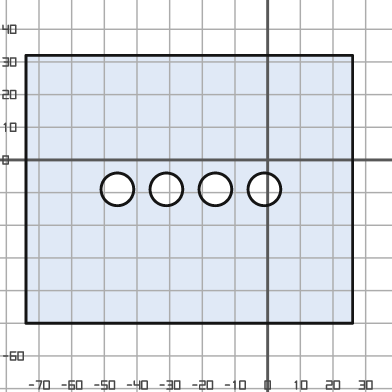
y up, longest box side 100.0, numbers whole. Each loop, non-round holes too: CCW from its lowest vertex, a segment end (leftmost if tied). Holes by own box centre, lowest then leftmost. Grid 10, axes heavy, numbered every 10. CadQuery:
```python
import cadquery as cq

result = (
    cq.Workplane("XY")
    .moveTo(-74.0, -50.0)
    .lineTo(26.0, -50.0)
    .lineTo(26.0, 32.0)
    .lineTo(-74.0, 32.0)
    .close()
    .moveTo(-46.0, -9.0)
    .circle(5.0)
    .moveTo(-31.0, -9.0)
    .circle(5.0)
    .moveTo(-16.0, -9.0)
    .circle(5.0)
    .moveTo(-1.0, -9.0)
    .circle(5.0)
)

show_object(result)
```